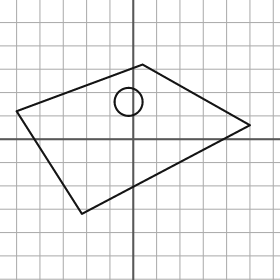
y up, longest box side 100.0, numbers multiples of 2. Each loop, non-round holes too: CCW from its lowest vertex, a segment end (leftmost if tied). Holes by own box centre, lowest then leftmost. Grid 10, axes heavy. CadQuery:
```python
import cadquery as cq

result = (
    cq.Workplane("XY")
    .moveTo(-22.0, -32.0)
    .lineTo(50.0, 6.0)
    .lineTo(4.0, 32.0)
    .lineTo(-50.0, 12.0)
    .close()
    .moveTo(-2.0, 16.0)
    .circle(6.0)
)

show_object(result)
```